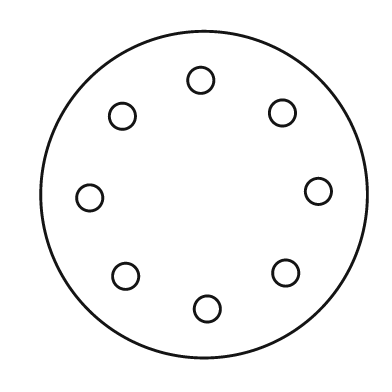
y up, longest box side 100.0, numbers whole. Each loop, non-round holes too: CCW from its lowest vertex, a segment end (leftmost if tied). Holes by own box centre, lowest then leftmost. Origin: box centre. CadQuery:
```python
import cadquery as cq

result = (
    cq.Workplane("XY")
    .moveTo(0.0, 0.0)
    .circle(50.0)
    .moveTo(1.0, -35.0)
    .circle(4.0)
    .moveTo(-24.0, -25.0)
    .circle(4.0)
    .moveTo(25.0, -24.0)
    .circle(4.0)
    .moveTo(-35.0, -1.0)
    .circle(4.0)
    .moveTo(35.0, 1.0)
    .circle(4.0)
    .moveTo(-25.0, 24.0)
    .circle(4.0)
    .moveTo(24.0, 25.0)
    .circle(4.0)
    .moveTo(-1.0, 35.0)
    .circle(4.0)
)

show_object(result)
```